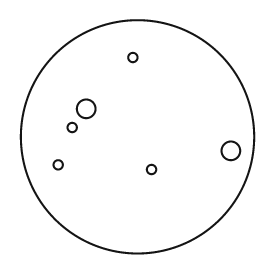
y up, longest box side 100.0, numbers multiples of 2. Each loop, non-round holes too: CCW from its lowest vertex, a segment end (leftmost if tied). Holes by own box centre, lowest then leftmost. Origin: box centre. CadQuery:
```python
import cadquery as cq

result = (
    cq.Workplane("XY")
    .moveTo(0.0, 0.0)
    .circle(50.0)
    .moveTo(6.0, -14.0)
    .circle(2.0)
    .moveTo(-34.0, -12.0)
    .circle(2.0)
    .moveTo(40.0, -6.0)
    .circle(4.0)
    .moveTo(-28.0, 4.0)
    .circle(2.0)
    .moveTo(-22.0, 12.0)
    .circle(4.0)
    .moveTo(-2.0, 34.0)
    .circle(2.0)
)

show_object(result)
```